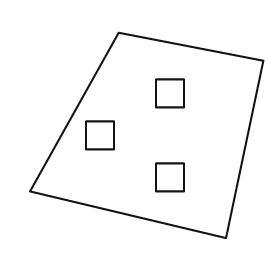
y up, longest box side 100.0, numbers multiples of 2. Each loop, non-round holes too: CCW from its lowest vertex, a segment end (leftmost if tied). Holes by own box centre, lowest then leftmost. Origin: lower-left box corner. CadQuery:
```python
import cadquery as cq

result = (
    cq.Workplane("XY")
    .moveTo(84.0, 0.0)
    .lineTo(100.0, 76.0)
    .lineTo(38.0, 88.0)
    .lineTo(0.0, 20.0)
    .close()
    .moveTo(54.0, 20.0)
    .lineTo(66.0, 20.0)
    .lineTo(66.0, 32.0)
    .lineTo(54.0, 32.0)
    .close()
    .moveTo(24.0, 38.0)
    .lineTo(36.0, 38.0)
    .lineTo(36.0, 50.0)
    .lineTo(24.0, 50.0)
    .close()
    .moveTo(54.0, 56.0)
    .lineTo(66.0, 56.0)
    .lineTo(66.0, 68.0)
    .lineTo(54.0, 68.0)
    .close()
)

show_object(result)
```